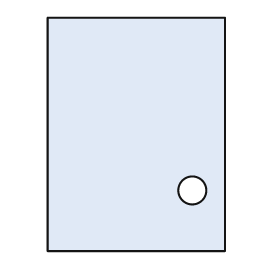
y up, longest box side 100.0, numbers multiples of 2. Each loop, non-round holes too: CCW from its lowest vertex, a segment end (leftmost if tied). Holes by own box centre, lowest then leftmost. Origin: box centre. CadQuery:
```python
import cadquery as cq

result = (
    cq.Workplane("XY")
    .moveTo(-38.0, -50.0)
    .lineTo(38.0, -50.0)
    .lineTo(38.0, 50.0)
    .lineTo(-38.0, 50.0)
    .close()
    .moveTo(24.0, -24.0)
    .circle(6.0)
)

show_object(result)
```